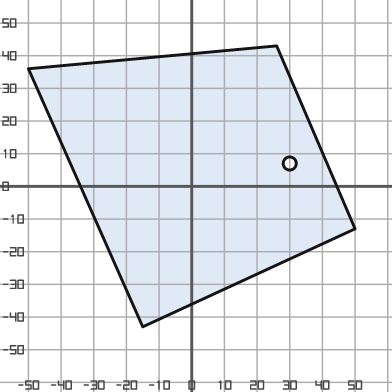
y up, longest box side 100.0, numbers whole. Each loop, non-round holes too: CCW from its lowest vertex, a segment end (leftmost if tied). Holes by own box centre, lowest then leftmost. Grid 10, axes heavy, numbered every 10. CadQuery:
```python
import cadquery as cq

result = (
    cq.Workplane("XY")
    .moveTo(-15.0, -43.0)
    .lineTo(50.0, -13.0)
    .lineTo(26.0, 43.0)
    .lineTo(-50.0, 36.0)
    .close()
    .moveTo(30.0, 7.0)
    .circle(2.0)
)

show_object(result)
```